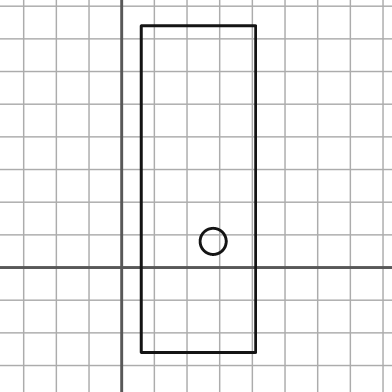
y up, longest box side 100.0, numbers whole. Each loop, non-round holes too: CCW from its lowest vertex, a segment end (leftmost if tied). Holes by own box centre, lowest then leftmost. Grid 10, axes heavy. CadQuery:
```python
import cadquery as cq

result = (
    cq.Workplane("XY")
    .moveTo(6.0, -26.0)
    .lineTo(41.0, -26.0)
    .lineTo(41.0, 74.0)
    .lineTo(6.0, 74.0)
    .close()
    .moveTo(28.0, 8.0)
    .circle(4.0)
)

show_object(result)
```